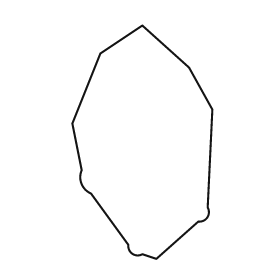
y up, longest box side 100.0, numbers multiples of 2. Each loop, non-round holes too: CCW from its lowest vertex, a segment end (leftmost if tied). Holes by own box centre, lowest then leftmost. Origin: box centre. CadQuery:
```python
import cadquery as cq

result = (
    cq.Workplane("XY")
    .moveTo(6.0, -50.0)
    .lineTo(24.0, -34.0)
    .threePointArc((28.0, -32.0), (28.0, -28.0))
    .lineTo(30.0, 14.0)
    .lineTo(20.0, 32.0)
    .lineTo(0.0, 50.0)
    .lineTo(-18.0, 38.0)
    .lineTo(-30.0, 8.0)
    .lineTo(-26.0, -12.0)
    .threePointArc((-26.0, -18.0), (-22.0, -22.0))
    .lineTo(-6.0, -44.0)
    .threePointArc((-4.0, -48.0), (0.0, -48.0))
    .close()
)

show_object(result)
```